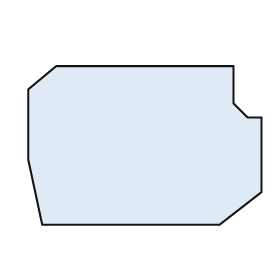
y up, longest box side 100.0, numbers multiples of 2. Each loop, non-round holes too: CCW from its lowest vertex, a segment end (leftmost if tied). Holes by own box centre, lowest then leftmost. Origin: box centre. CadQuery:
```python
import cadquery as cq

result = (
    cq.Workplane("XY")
    .moveTo(-44.0, -34.0)
    .lineTo(32.0, -34.0)
    .lineTo(50.0, -20.0)
    .lineTo(50.0, 12.0)
    .lineTo(44.0, 12.0)
    .lineTo(38.0, 18.0)
    .lineTo(38.0, 34.0)
    .lineTo(-38.0, 34.0)
    .lineTo(-50.0, 24.0)
    .lineTo(-50.0, -6.0)
    .close()
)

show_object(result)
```